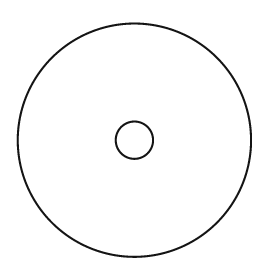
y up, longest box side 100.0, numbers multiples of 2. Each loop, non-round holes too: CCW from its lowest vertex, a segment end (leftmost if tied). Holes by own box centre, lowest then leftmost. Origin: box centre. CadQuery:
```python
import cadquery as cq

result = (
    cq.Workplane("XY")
    .moveTo(0.0, 0.0)
    .circle(50.0)
    .moveTo(0.0, 0.0)
    .circle(8.0)
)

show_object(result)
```